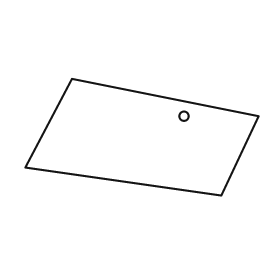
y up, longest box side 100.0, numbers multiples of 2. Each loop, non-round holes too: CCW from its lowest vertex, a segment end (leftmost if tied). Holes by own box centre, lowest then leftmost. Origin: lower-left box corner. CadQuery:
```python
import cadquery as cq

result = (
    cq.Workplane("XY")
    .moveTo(84.0, 0.0)
    .lineTo(100.0, 34.0)
    .lineTo(20.0, 50.0)
    .lineTo(0.0, 12.0)
    .close()
    .moveTo(68.0, 34.0)
    .circle(2.0)
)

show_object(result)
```